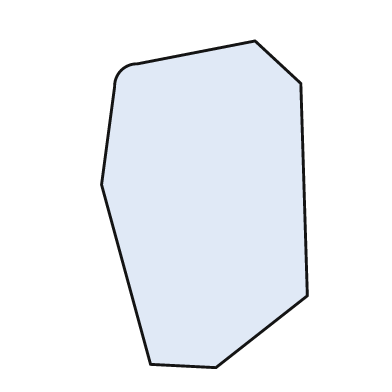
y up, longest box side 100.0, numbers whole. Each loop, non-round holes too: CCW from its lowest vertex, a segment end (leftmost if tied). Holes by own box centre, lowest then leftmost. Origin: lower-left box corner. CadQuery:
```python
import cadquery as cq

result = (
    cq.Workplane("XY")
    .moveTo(35.0, 0.0)
    .lineTo(63.0, 22.0)
    .lineTo(61.0, 87.0)
    .lineTo(47.0, 100.0)
    .lineTo(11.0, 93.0)
    .threePointArc((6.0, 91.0), (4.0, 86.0))
    .lineTo(0.0, 56.0)
    .lineTo(15.0, 1.0)
    .close()
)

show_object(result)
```